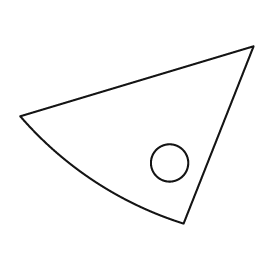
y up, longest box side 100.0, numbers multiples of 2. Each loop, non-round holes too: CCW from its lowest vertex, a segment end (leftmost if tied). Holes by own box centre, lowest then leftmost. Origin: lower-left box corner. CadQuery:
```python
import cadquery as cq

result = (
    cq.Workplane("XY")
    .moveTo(70.0, 0.0)
    .lineTo(100.0, 76.0)
    .lineTo(0.0, 46.0)
    .threePointArc((32.0, 18.0), (70.0, 0.0))
    .close()
    .moveTo(64.0, 26.0)
    .circle(8.0)
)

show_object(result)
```